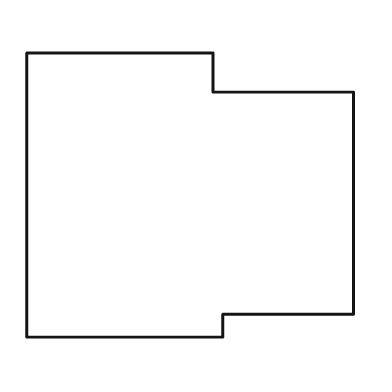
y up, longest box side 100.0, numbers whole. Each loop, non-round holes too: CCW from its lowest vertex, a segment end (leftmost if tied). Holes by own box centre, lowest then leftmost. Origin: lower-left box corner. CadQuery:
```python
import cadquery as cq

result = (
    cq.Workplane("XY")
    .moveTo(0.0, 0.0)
    .lineTo(60.0, 0.0)
    .lineTo(60.0, 7.0)
    .lineTo(100.0, 7.0)
    .lineTo(100.0, 75.0)
    .lineTo(57.0, 75.0)
    .lineTo(57.0, 87.0)
    .lineTo(0.0, 87.0)
    .close()
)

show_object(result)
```